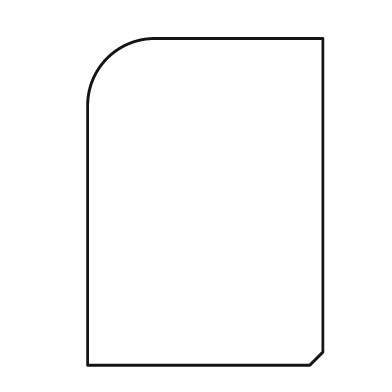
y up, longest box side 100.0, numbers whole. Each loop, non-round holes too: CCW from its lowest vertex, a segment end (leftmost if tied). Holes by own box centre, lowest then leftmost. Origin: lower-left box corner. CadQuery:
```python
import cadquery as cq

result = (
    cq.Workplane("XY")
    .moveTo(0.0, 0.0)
    .lineTo(68.0, 0.0)
    .lineTo(72.0, 4.0)
    .lineTo(72.0, 100.0)
    .lineTo(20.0, 100.0)
    .threePointArc((6.0, 94.0), (0.0, 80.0))
    .close()
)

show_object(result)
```